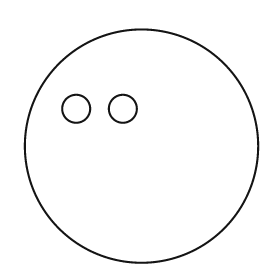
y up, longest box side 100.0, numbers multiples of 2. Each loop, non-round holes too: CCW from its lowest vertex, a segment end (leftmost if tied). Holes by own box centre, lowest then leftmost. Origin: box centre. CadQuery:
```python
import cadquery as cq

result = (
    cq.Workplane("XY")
    .moveTo(0.0, 0.0)
    .circle(50.0)
    .moveTo(-28.0, 16.0)
    .circle(6.0)
    .moveTo(-8.0, 16.0)
    .circle(6.0)
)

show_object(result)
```